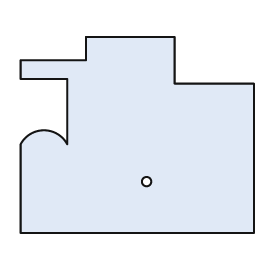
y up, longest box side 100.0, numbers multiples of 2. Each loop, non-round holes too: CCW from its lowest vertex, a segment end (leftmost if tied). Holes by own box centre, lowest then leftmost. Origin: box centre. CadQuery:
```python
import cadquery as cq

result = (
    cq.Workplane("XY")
    .moveTo(-50.0, -42.0)
    .lineTo(50.0, -42.0)
    .lineTo(50.0, 22.0)
    .lineTo(16.0, 22.0)
    .lineTo(16.0, 42.0)
    .lineTo(-22.0, 42.0)
    .lineTo(-22.0, 32.0)
    .lineTo(-50.0, 32.0)
    .lineTo(-50.0, 24.0)
    .lineTo(-30.0, 24.0)
    .lineTo(-30.0, -4.0)
    .threePointArc((-40.0, 2.0), (-50.0, -4.0))
    .close()
    .moveTo(4.0, -20.0)
    .circle(2.0)
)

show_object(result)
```